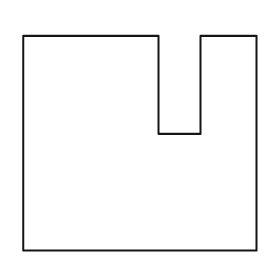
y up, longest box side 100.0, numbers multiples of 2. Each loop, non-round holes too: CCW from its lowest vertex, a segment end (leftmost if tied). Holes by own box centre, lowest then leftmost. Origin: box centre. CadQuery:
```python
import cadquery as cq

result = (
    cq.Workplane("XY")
    .moveTo(-50.0, -46.0)
    .lineTo(50.0, -46.0)
    .lineTo(50.0, 46.0)
    .lineTo(26.0, 46.0)
    .lineTo(26.0, 4.0)
    .lineTo(8.0, 4.0)
    .lineTo(8.0, 46.0)
    .lineTo(-50.0, 46.0)
    .close()
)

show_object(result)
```